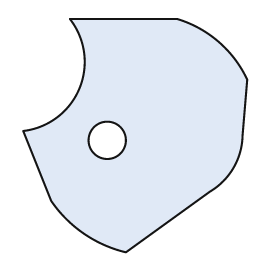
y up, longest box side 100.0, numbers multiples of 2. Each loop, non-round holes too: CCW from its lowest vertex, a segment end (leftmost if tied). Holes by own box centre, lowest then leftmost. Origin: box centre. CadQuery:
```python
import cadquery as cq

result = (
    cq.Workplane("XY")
    .moveTo(-4.0, -50.0)
    .lineTo(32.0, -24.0)
    .threePointArc((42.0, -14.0), (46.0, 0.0))
    .lineTo(48.0, 24.0)
    .threePointArc((36.0, 40.0), (18.0, 50.0))
    .lineTo(-28.0, 50.0)
    .threePointArc((-24.0, 20.0), (-48.0, 2.0))
    .lineTo(-36.0, -28.0)
    .threePointArc((-22.0, -42.0), (-4.0, -50.0))
    .close()
    .moveTo(-12.0, -2.0)
    .circle(8.0)
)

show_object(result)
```